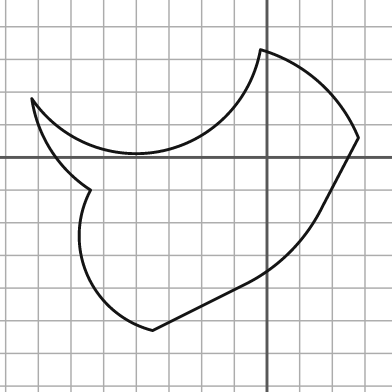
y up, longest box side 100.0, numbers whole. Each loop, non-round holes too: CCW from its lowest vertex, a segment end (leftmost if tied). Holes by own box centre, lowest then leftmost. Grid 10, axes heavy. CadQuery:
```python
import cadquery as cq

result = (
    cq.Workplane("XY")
    .moveTo(-35.0, -53.0)
    .lineTo(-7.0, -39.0)
    .threePointArc((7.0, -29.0), (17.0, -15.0))
    .lineTo(28.0, 6.0)
    .threePointArc((16.0, 23.0), (-2.0, 33.0))
    .threePointArc((-32.0, 2.0), (-72.0, 18.0))
    .threePointArc((-66.0, 2.0), (-54.0, -10.0))
    .threePointArc((-55.0, -36.0), (-35.0, -53.0))
    .close()
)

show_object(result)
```